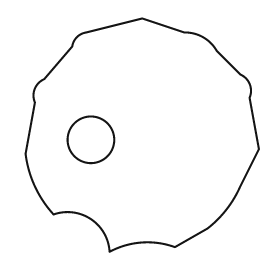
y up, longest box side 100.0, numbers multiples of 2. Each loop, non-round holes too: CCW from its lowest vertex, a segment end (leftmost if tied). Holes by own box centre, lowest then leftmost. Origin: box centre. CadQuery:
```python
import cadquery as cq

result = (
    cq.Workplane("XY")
    .moveTo(-14.0, -50.0)
    .threePointArc((0.0, -46.0), (14.0, -48.0))
    .lineTo(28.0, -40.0)
    .threePointArc((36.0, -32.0), (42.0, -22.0))
    .lineTo(50.0, -6.0)
    .lineTo(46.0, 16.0)
    .threePointArc((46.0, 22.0), (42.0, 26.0))
    .lineTo(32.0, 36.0)
    .threePointArc((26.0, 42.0), (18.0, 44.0))
    .lineTo(0.0, 50.0)
    .lineTo(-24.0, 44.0)
    .threePointArc((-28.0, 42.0), (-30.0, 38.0))
    .lineTo(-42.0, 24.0)
    .threePointArc((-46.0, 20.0), (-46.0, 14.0))
    .lineTo(-50.0, -8.0)
    .threePointArc((-46.0, -22.0), (-38.0, -34.0))
    .threePointArc((-22.0, -36.0), (-14.0, -50.0))
    .close()
    .moveTo(-22.0, -2.0)
    .circle(10.0)
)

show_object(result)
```